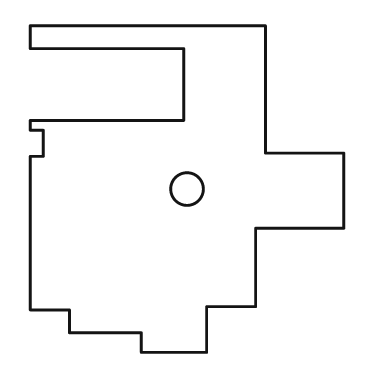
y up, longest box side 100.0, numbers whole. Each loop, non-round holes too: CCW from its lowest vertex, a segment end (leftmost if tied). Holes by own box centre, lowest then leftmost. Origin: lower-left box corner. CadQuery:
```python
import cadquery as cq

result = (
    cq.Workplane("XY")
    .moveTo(34.0, 0.0)
    .lineTo(54.0, 0.0)
    .lineTo(54.0, 14.0)
    .lineTo(69.0, 14.0)
    .lineTo(69.0, 38.0)
    .lineTo(96.0, 38.0)
    .lineTo(96.0, 61.0)
    .lineTo(72.0, 61.0)
    .lineTo(72.0, 100.0)
    .lineTo(0.0, 100.0)
    .lineTo(0.0, 93.0)
    .lineTo(47.0, 93.0)
    .lineTo(47.0, 71.0)
    .lineTo(0.0, 71.0)
    .lineTo(0.0, 68.0)
    .lineTo(4.0, 68.0)
    .lineTo(4.0, 60.0)
    .lineTo(0.0, 60.0)
    .lineTo(0.0, 13.0)
    .lineTo(12.0, 13.0)
    .lineTo(12.0, 6.0)
    .lineTo(34.0, 6.0)
    .close()
    .moveTo(48.0, 50.0)
    .circle(5.0)
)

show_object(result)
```